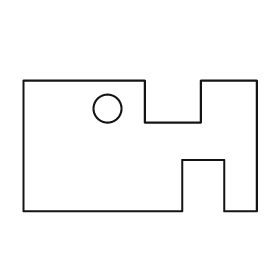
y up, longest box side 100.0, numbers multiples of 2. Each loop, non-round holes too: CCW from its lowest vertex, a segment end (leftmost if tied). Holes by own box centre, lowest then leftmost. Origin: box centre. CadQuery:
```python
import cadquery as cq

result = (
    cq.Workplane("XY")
    .moveTo(-50.0, -28.0)
    .lineTo(18.0, -28.0)
    .lineTo(18.0, -6.0)
    .lineTo(36.0, -6.0)
    .lineTo(36.0, -28.0)
    .lineTo(50.0, -28.0)
    .lineTo(50.0, 28.0)
    .lineTo(26.0, 28.0)
    .lineTo(26.0, 10.0)
    .lineTo(2.0, 10.0)
    .lineTo(2.0, 28.0)
    .lineTo(-50.0, 28.0)
    .close()
    .moveTo(-14.0, 16.0)
    .circle(6.0)
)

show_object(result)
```